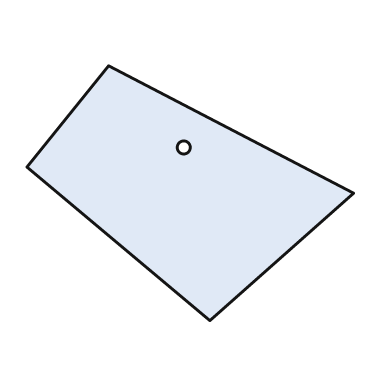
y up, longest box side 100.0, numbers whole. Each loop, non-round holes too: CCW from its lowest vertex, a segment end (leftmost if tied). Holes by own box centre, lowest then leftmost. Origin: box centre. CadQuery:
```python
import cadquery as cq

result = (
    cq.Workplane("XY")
    .moveTo(6.0, -39.0)
    .lineTo(50.0, 0.0)
    .lineTo(-25.0, 39.0)
    .lineTo(-50.0, 8.0)
    .close()
    .moveTo(-2.0, 14.0)
    .circle(2.0)
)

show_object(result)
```